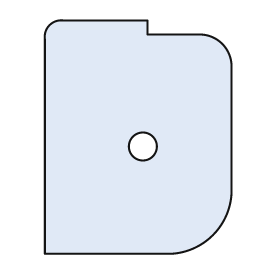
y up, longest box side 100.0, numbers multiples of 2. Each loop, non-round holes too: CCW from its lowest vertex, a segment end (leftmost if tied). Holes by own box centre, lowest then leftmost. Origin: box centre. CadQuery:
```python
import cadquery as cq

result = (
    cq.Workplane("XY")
    .moveTo(-40.0, -50.0)
    .lineTo(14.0, -50.0)
    .threePointArc((32.0, -42.0), (40.0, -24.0))
    .lineTo(40.0, 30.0)
    .threePointArc((36.0, 40.0), (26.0, 44.0))
    .lineTo(4.0, 44.0)
    .lineTo(4.0, 50.0)
    .lineTo(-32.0, 50.0)
    .threePointArc((-38.0, 48.0), (-40.0, 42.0))
    .close()
    .moveTo(2.0, -4.0)
    .circle(6.0)
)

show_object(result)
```